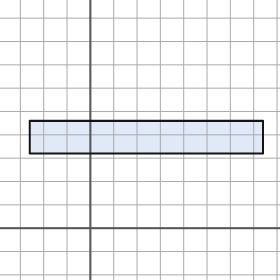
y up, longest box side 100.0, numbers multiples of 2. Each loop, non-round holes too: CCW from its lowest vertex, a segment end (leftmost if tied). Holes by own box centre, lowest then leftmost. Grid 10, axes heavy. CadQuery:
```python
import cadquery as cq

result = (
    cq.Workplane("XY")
    .moveTo(-26.0, 32.0)
    .lineTo(74.0, 32.0)
    .lineTo(74.0, 46.0)
    .lineTo(-26.0, 46.0)
    .close()
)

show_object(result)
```